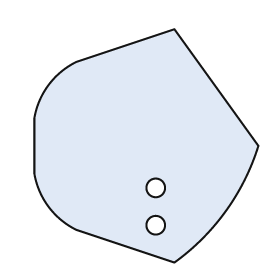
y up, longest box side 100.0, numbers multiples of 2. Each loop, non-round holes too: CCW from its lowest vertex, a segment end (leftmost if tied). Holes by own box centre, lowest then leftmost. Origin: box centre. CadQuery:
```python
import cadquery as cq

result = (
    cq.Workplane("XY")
    .moveTo(12.0, -50.0)
    .threePointArc((34.0, -28.0), (48.0, 0.0))
    .lineTo(12.0, 50.0)
    .lineTo(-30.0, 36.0)
    .threePointArc((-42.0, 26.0), (-48.0, 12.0))
    .lineTo(-48.0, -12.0)
    .threePointArc((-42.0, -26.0), (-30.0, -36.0))
    .close()
    .moveTo(4.0, -34.0)
    .circle(4.0)
    .moveTo(4.0, -18.0)
    .circle(4.0)
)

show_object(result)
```